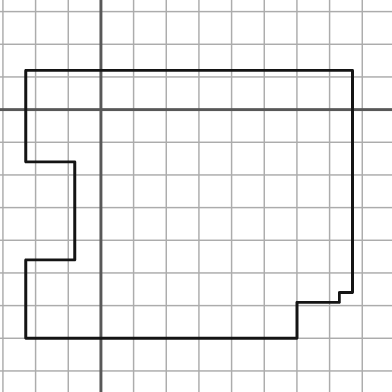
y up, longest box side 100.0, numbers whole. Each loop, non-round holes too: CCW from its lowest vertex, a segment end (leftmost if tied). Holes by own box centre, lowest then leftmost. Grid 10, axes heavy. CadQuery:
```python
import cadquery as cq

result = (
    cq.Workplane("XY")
    .moveTo(-23.0, -70.0)
    .lineTo(60.0, -70.0)
    .lineTo(60.0, -59.0)
    .lineTo(73.0, -59.0)
    .lineTo(73.0, -56.0)
    .lineTo(77.0, -56.0)
    .lineTo(77.0, 12.0)
    .lineTo(-23.0, 12.0)
    .lineTo(-23.0, -16.0)
    .lineTo(-8.0, -16.0)
    .lineTo(-8.0, -46.0)
    .lineTo(-23.0, -46.0)
    .close()
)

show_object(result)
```